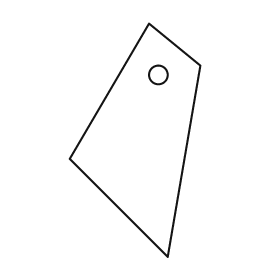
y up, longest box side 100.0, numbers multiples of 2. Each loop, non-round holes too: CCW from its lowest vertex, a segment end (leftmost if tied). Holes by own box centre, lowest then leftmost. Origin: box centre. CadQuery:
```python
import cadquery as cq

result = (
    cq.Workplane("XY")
    .moveTo(14.0, -50.0)
    .lineTo(28.0, 32.0)
    .lineTo(6.0, 50.0)
    .lineTo(-28.0, -8.0)
    .close()
    .moveTo(10.0, 28.0)
    .circle(4.0)
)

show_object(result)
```